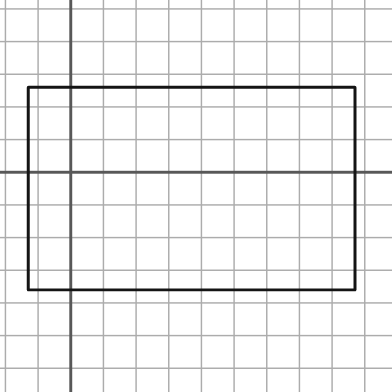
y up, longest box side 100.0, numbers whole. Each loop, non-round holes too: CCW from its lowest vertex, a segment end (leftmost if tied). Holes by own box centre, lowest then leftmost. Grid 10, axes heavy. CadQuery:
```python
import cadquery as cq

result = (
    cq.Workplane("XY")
    .moveTo(-13.0, -36.0)
    .lineTo(87.0, -36.0)
    .lineTo(87.0, 26.0)
    .lineTo(-13.0, 26.0)
    .close()
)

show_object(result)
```